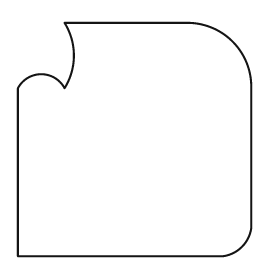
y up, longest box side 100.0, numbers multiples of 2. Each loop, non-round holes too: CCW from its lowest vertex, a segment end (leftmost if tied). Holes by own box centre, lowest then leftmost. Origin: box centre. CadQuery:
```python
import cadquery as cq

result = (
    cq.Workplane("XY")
    .moveTo(-50.0, -50.0)
    .lineTo(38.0, -50.0)
    .threePointArc((46.0, -46.0), (50.0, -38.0))
    .lineTo(50.0, 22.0)
    .threePointArc((42.0, 42.0), (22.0, 50.0))
    .lineTo(-30.0, 50.0)
    .threePointArc((-26.0, 36.0), (-30.0, 22.0))
    .threePointArc((-40.0, 28.0), (-50.0, 22.0))
    .close()
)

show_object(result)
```